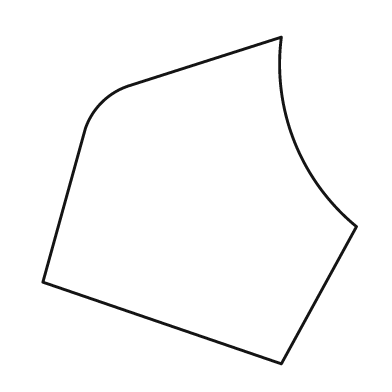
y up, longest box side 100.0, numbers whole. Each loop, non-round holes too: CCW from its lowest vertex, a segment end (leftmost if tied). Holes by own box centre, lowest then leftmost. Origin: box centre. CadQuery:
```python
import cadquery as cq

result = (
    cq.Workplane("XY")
    .moveTo(25.0, -50.0)
    .lineTo(48.0, -8.0)
    .threePointArc((29.0, 18.0), (25.0, 50.0))
    .lineTo(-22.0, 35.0)
    .threePointArc((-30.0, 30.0), (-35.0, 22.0))
    .lineTo(-48.0, -25.0)
    .close()
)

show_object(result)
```